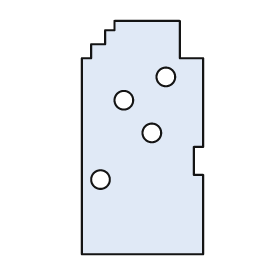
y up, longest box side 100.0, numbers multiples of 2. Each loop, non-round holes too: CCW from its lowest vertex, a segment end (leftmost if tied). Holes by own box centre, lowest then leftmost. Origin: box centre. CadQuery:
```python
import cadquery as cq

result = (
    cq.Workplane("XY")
    .moveTo(-26.0, -50.0)
    .lineTo(26.0, -50.0)
    .lineTo(26.0, -16.0)
    .lineTo(22.0, -16.0)
    .lineTo(22.0, -4.0)
    .lineTo(26.0, -4.0)
    .lineTo(26.0, 34.0)
    .lineTo(16.0, 34.0)
    .lineTo(16.0, 50.0)
    .lineTo(-12.0, 50.0)
    .lineTo(-12.0, 46.0)
    .lineTo(-16.0, 46.0)
    .lineTo(-16.0, 40.0)
    .lineTo(-22.0, 40.0)
    .lineTo(-22.0, 34.0)
    .lineTo(-26.0, 34.0)
    .close()
    .moveTo(-18.0, -18.0)
    .circle(4.0)
    .moveTo(4.0, 2.0)
    .circle(4.0)
    .moveTo(-8.0, 16.0)
    .circle(4.0)
    .moveTo(10.0, 26.0)
    .circle(4.0)
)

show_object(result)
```